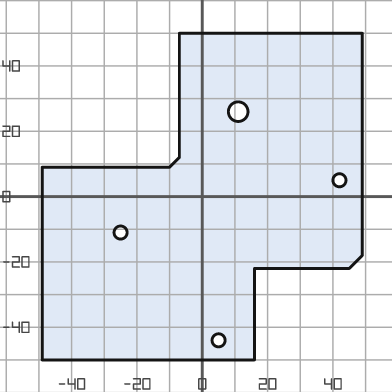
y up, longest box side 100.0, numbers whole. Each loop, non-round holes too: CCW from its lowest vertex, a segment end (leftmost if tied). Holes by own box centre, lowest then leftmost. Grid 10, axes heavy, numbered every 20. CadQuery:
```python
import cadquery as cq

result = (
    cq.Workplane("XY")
    .moveTo(-49.0, -50.0)
    .lineTo(16.0, -50.0)
    .lineTo(16.0, -22.0)
    .lineTo(45.0, -22.0)
    .lineTo(49.0, -18.0)
    .lineTo(49.0, 50.0)
    .lineTo(-7.0, 50.0)
    .lineTo(-7.0, 12.0)
    .lineTo(-10.0, 9.0)
    .lineTo(-49.0, 9.0)
    .close()
    .moveTo(5.0, -44.0)
    .circle(2.0)
    .moveTo(-25.0, -11.0)
    .circle(2.0)
    .moveTo(42.0, 5.0)
    .circle(2.0)
    .moveTo(11.0, 26.0)
    .circle(3.0)
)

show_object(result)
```